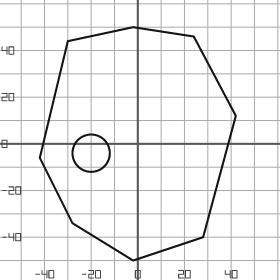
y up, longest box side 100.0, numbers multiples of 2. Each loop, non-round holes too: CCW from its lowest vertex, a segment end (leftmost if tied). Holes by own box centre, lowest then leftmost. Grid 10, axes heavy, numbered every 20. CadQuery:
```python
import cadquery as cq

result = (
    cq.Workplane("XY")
    .moveTo(-2.0, -50.0)
    .lineTo(28.0, -40.0)
    .lineTo(42.0, 12.0)
    .lineTo(24.0, 46.0)
    .lineTo(-2.0, 50.0)
    .lineTo(-30.0, 44.0)
    .lineTo(-42.0, -6.0)
    .lineTo(-28.0, -34.0)
    .close()
    .moveTo(-20.0, -4.0)
    .circle(8.0)
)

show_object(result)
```